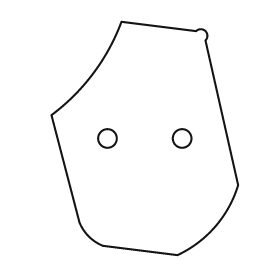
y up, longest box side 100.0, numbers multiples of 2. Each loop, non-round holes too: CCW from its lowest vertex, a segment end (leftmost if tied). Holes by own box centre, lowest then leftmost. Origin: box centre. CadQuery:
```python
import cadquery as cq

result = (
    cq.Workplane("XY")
    .moveTo(14.0, -50.0)
    .threePointArc((30.0, -38.0), (40.0, -20.0))
    .lineTo(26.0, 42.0)
    .threePointArc((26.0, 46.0), (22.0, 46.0))
    .lineTo(-10.0, 50.0)
    .threePointArc((-22.0, 28.0), (-40.0, 10.0))
    .lineTo(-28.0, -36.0)
    .threePointArc((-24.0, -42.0), (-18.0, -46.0))
    .close()
    .moveTo(-16.0, 0.0)
    .circle(4.0)
    .moveTo(16.0, 0.0)
    .circle(4.0)
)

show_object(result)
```